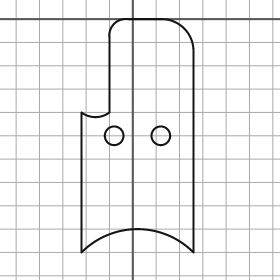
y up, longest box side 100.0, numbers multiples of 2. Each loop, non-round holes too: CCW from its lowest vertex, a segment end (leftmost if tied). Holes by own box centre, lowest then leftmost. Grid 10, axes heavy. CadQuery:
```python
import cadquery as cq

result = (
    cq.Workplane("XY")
    .moveTo(-22.0, -100.0)
    .threePointArc((2.0, -90.0), (26.0, -100.0))
    .lineTo(26.0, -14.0)
    .threePointArc((22.0, -4.0), (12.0, 0.0))
    .lineTo(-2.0, 0.0)
    .threePointArc((-8.0, -2.0), (-10.0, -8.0))
    .lineTo(-10.0, -40.0)
    .threePointArc((-16.0, -42.0), (-22.0, -40.0))
    .close()
    .moveTo(-8.0, -50.0)
    .circle(4.0)
    .moveTo(12.0, -50.0)
    .circle(4.0)
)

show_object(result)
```